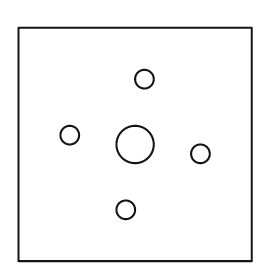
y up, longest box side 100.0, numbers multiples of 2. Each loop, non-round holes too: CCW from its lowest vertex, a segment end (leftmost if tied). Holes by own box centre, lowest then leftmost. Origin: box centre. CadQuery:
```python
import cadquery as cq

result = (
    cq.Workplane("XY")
    .moveTo(-50.0, -50.0)
    .lineTo(50.0, -50.0)
    .lineTo(50.0, 50.0)
    .lineTo(-50.0, 50.0)
    .close()
    .moveTo(-4.0, -28.0)
    .circle(4.0)
    .moveTo(28.0, -4.0)
    .circle(4.0)
    .moveTo(0.0, 0.0)
    .circle(8.0)
    .moveTo(-28.0, 4.0)
    .circle(4.0)
    .moveTo(4.0, 28.0)
    .circle(4.0)
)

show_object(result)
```